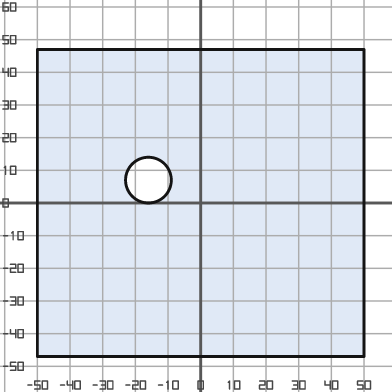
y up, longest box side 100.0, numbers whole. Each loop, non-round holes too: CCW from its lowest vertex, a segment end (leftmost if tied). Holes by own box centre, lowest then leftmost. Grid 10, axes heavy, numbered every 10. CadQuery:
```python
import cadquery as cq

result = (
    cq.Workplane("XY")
    .moveTo(-50.0, -47.0)
    .lineTo(50.0, -47.0)
    .lineTo(50.0, 47.0)
    .lineTo(-50.0, 47.0)
    .close()
    .moveTo(-16.0, 7.0)
    .circle(7.0)
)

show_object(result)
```